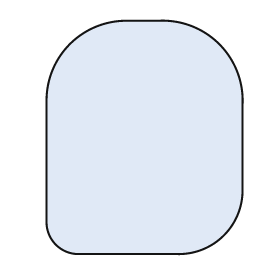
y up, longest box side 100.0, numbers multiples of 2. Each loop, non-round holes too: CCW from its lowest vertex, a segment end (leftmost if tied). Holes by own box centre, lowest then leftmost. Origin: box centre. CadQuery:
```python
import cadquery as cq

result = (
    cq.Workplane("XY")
    .moveTo(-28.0, -50.0)
    .lineTo(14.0, -50.0)
    .threePointArc((34.0, -42.0), (42.0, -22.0))
    .lineTo(42.0, 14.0)
    .threePointArc((32.0, 40.0), (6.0, 50.0))
    .lineTo(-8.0, 50.0)
    .threePointArc((-32.0, 40.0), (-42.0, 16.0))
    .lineTo(-42.0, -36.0)
    .threePointArc((-38.0, -46.0), (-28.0, -50.0))
    .close()
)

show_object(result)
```